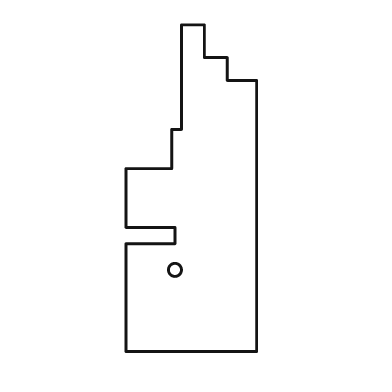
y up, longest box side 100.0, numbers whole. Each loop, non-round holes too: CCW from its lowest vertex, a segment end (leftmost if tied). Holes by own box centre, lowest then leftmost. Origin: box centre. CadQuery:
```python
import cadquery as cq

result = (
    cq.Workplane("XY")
    .moveTo(-20.0, -50.0)
    .lineTo(20.0, -50.0)
    .lineTo(20.0, 33.0)
    .lineTo(11.0, 33.0)
    .lineTo(11.0, 40.0)
    .lineTo(4.0, 40.0)
    .lineTo(4.0, 50.0)
    .lineTo(-3.0, 50.0)
    .lineTo(-3.0, 18.0)
    .lineTo(-6.0, 18.0)
    .lineTo(-6.0, 6.0)
    .lineTo(-20.0, 6.0)
    .lineTo(-20.0, -12.0)
    .lineTo(-5.0, -12.0)
    .lineTo(-5.0, -17.0)
    .lineTo(-20.0, -17.0)
    .close()
    .moveTo(-5.0, -25.0)
    .circle(2.0)
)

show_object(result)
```